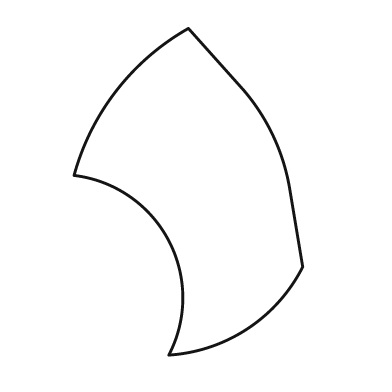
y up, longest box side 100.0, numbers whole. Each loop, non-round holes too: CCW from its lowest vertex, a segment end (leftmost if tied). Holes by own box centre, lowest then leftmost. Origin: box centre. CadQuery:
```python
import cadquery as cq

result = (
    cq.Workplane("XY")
    .moveTo(-6.0, -50.0)
    .threePointArc((18.0, -42.0), (35.0, -23.0))
    .lineTo(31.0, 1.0)
    .threePointArc((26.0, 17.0), (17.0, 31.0))
    .lineTo(0.0, 50.0)
    .threePointArc((-22.0, 31.0), (-35.0, 5.0))
    .threePointArc((-6.0, -15.0), (-6.0, -50.0))
    .close()
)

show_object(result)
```